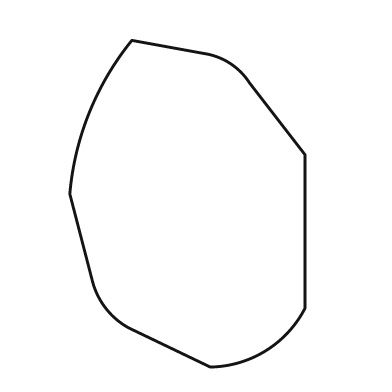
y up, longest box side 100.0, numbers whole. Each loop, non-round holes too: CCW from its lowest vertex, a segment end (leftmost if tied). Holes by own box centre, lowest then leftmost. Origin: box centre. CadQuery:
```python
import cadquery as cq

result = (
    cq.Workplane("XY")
    .moveTo(7.0, -50.0)
    .threePointArc((24.0, -45.0), (36.0, -32.0))
    .lineTo(36.0, 15.0)
    .lineTo(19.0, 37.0)
    .threePointArc((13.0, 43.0), (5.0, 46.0))
    .lineTo(-17.0, 50.0)
    .threePointArc((-30.0, 28.0), (-36.0, 3.0))
    .lineTo(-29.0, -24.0)
    .threePointArc((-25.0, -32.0), (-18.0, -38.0))
    .close()
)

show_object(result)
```